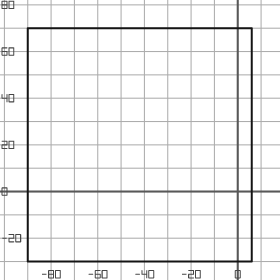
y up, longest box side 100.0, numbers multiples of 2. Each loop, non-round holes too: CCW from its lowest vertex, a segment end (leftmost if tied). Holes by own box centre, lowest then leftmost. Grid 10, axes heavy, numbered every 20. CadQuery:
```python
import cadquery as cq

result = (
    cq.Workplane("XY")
    .moveTo(-90.0, -30.0)
    .lineTo(6.0, -30.0)
    .lineTo(6.0, 70.0)
    .lineTo(-90.0, 70.0)
    .close()
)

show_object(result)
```